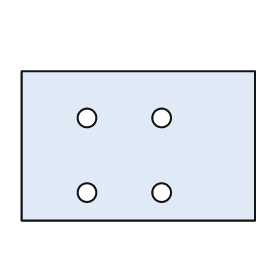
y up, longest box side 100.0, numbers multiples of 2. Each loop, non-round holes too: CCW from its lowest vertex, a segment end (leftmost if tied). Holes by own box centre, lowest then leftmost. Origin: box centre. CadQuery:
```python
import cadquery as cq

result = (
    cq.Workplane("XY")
    .moveTo(-50.0, -32.0)
    .lineTo(50.0, -32.0)
    .lineTo(50.0, 32.0)
    .lineTo(-50.0, 32.0)
    .close()
    .moveTo(-22.0, -20.0)
    .circle(4.0)
    .moveTo(10.0, -20.0)
    .circle(4.0)
    .moveTo(-22.0, 12.0)
    .circle(4.0)
    .moveTo(10.0, 12.0)
    .circle(4.0)
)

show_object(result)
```